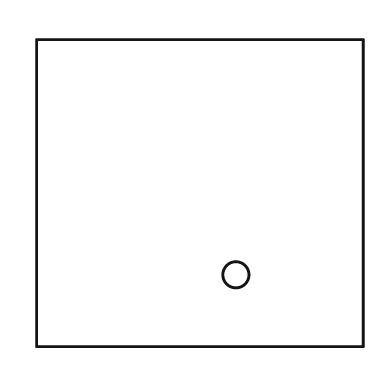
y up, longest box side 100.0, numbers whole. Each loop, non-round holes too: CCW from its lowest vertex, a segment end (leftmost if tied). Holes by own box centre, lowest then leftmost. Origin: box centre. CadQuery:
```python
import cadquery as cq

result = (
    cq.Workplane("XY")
    .moveTo(-50.0, -47.0)
    .lineTo(50.0, -47.0)
    .lineTo(50.0, 47.0)
    .lineTo(-50.0, 47.0)
    .close()
    .moveTo(11.0, -25.0)
    .circle(4.0)
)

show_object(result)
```